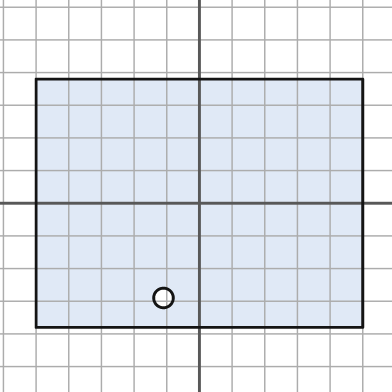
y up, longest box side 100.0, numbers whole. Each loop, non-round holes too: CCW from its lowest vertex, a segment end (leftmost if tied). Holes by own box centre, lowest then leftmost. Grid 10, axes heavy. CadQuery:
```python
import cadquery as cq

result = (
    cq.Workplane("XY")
    .moveTo(-50.0, -38.0)
    .lineTo(50.0, -38.0)
    .lineTo(50.0, 38.0)
    .lineTo(-50.0, 38.0)
    .close()
    .moveTo(-11.0, -29.0)
    .circle(3.0)
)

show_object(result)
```